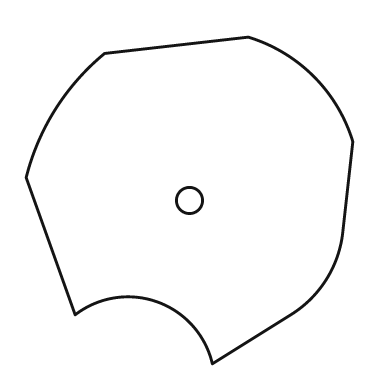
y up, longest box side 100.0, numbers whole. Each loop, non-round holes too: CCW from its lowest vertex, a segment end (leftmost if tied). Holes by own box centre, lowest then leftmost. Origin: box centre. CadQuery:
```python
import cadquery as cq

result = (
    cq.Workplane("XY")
    .moveTo(7.0, -50.0)
    .lineTo(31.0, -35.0)
    .threePointArc((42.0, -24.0), (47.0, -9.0))
    .lineTo(50.0, 18.0)
    .threePointArc((38.0, 38.0), (18.0, 50.0))
    .lineTo(-26.0, 45.0)
    .threePointArc((-41.0, 28.0), (-50.0, 7.0))
    .lineTo(-35.0, -35.0)
    .threePointArc((-10.0, -31.0), (7.0, -50.0))
    .close()
    .moveTo(0.0, 0.0)
    .circle(4.0)
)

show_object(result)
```